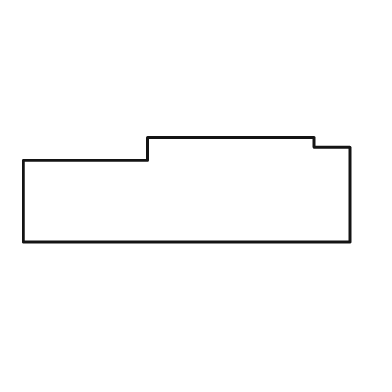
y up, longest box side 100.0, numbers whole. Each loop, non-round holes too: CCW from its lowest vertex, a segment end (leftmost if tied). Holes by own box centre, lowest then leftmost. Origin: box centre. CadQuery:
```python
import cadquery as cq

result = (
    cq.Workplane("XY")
    .moveTo(-50.0, -16.0)
    .lineTo(50.0, -16.0)
    .lineTo(50.0, 13.0)
    .lineTo(39.0, 13.0)
    .lineTo(39.0, 16.0)
    .lineTo(-12.0, 16.0)
    .lineTo(-12.0, 9.0)
    .lineTo(-50.0, 9.0)
    .close()
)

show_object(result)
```